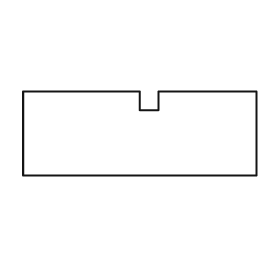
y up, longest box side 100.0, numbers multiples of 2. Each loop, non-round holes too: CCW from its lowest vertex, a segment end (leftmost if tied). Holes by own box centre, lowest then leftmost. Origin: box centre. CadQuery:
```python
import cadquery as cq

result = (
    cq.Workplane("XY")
    .moveTo(-50.0, -18.0)
    .lineTo(50.0, -18.0)
    .lineTo(50.0, 18.0)
    .lineTo(8.0, 18.0)
    .lineTo(8.0, 10.0)
    .lineTo(0.0, 10.0)
    .lineTo(0.0, 18.0)
    .lineTo(-50.0, 18.0)
    .close()
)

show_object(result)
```